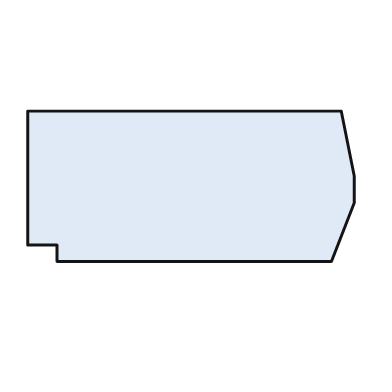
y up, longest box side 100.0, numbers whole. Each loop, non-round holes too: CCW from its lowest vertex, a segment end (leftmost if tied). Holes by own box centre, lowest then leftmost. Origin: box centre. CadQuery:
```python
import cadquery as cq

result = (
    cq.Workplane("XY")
    .moveTo(-41.0, -23.0)
    .lineTo(43.0, -23.0)
    .lineTo(50.0, -5.0)
    .lineTo(50.0, 3.0)
    .lineTo(46.0, 23.0)
    .lineTo(-50.0, 23.0)
    .lineTo(-50.0, -18.0)
    .lineTo(-41.0, -18.0)
    .close()
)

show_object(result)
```